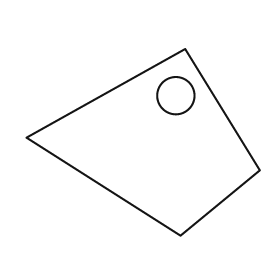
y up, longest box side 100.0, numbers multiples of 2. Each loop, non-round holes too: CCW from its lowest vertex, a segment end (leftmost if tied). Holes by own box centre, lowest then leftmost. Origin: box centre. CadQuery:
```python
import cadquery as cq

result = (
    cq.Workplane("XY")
    .moveTo(16.0, -40.0)
    .lineTo(50.0, -12.0)
    .lineTo(18.0, 40.0)
    .lineTo(-50.0, 2.0)
    .close()
    .moveTo(14.0, 20.0)
    .circle(8.0)
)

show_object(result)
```